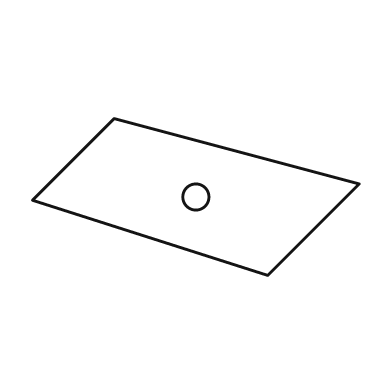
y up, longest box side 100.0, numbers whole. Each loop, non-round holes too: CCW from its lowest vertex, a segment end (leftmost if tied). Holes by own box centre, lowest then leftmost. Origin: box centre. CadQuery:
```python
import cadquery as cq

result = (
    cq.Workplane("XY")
    .moveTo(22.0, -24.0)
    .lineTo(50.0, 4.0)
    .lineTo(-25.0, 24.0)
    .lineTo(-50.0, -1.0)
    .close()
    .moveTo(0.0, 0.0)
    .circle(4.0)
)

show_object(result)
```